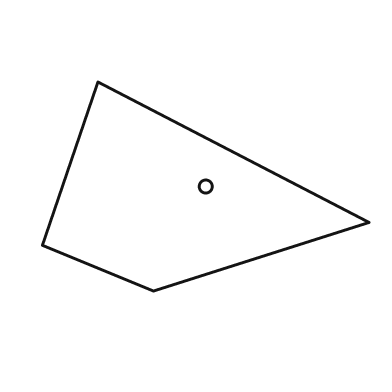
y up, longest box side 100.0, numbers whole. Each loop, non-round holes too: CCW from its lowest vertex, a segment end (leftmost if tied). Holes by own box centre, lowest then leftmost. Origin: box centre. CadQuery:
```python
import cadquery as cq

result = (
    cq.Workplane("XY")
    .moveTo(-16.0, -32.0)
    .lineTo(50.0, -11.0)
    .lineTo(-33.0, 32.0)
    .lineTo(-50.0, -18.0)
    .close()
    .moveTo(0.0, 0.0)
    .circle(2.0)
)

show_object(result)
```